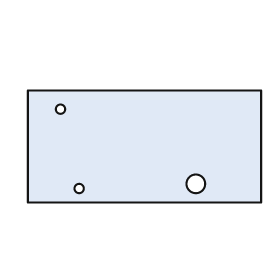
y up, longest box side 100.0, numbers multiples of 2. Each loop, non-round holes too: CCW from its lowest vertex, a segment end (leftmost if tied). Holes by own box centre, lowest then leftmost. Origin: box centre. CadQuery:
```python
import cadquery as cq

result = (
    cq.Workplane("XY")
    .moveTo(-50.0, -24.0)
    .lineTo(50.0, -24.0)
    .lineTo(50.0, 24.0)
    .lineTo(-50.0, 24.0)
    .close()
    .moveTo(-28.0, -18.0)
    .circle(2.0)
    .moveTo(22.0, -16.0)
    .circle(4.0)
    .moveTo(-36.0, 16.0)
    .circle(2.0)
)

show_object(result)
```